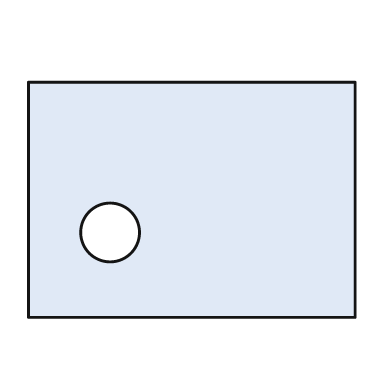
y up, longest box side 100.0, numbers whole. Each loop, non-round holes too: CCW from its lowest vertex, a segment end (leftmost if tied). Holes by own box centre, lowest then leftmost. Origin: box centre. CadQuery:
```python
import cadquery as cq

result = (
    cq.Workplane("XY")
    .moveTo(-50.0, -36.0)
    .lineTo(50.0, -36.0)
    .lineTo(50.0, 36.0)
    .lineTo(-50.0, 36.0)
    .close()
    .moveTo(-25.0, -10.0)
    .circle(9.0)
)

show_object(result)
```